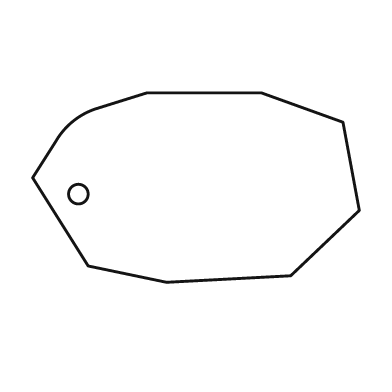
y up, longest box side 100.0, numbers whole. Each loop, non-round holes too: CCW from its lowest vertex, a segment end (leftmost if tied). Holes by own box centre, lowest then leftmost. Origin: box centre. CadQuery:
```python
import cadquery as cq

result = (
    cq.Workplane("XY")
    .moveTo(-9.0, -29.0)
    .lineTo(29.0, -27.0)
    .lineTo(50.0, -7.0)
    .lineTo(45.0, 20.0)
    .lineTo(20.0, 29.0)
    .lineTo(-15.0, 29.0)
    .lineTo(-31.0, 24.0)
    .threePointArc((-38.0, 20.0), (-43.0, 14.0))
    .lineTo(-50.0, 3.0)
    .lineTo(-33.0, -24.0)
    .close()
    .moveTo(-36.0, -2.0)
    .circle(3.0)
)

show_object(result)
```